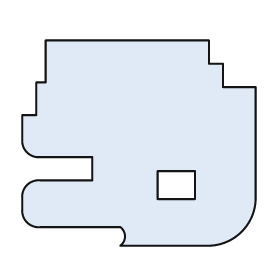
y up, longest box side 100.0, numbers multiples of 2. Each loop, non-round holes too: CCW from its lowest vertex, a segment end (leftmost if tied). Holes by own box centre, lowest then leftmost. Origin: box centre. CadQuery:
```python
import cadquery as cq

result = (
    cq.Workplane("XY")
    .moveTo(-8.0, -44.0)
    .lineTo(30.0, -44.0)
    .threePointArc((44.0, -38.0), (50.0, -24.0))
    .lineTo(50.0, 24.0)
    .lineTo(36.0, 24.0)
    .lineTo(36.0, 34.0)
    .lineTo(30.0, 34.0)
    .lineTo(30.0, 44.0)
    .lineTo(-40.0, 44.0)
    .lineTo(-40.0, 26.0)
    .lineTo(-44.0, 26.0)
    .lineTo(-44.0, 12.0)
    .lineTo(-50.0, 12.0)
    .lineTo(-50.0, 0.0)
    .threePointArc((-48.0, -4.0), (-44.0, -6.0))
    .lineTo(-20.0, -6.0)
    .lineTo(-20.0, -16.0)
    .lineTo(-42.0, -16.0)
    .threePointArc((-48.0, -18.0), (-50.0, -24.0))
    .lineTo(-50.0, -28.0)
    .threePointArc((-48.0, -34.0), (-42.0, -36.0))
    .lineTo(-8.0, -36.0)
    .threePointArc((-6.0, -40.0), (-8.0, -44.0))
    .close()
    .moveTo(8.0, -24.0)
    .lineTo(24.0, -24.0)
    .lineTo(24.0, -12.0)
    .lineTo(8.0, -12.0)
    .close()
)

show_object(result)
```